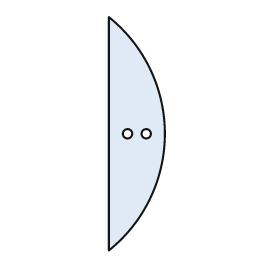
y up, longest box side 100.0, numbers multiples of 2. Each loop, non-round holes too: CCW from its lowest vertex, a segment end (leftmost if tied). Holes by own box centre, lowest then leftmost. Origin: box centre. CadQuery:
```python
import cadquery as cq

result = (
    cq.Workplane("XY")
    .moveTo(-12.0, -50.0)
    .threePointArc((12.0, 0.0), (-12.0, 50.0))
    .close()
    .moveTo(-4.0, 0.0)
    .circle(2.0)
    .moveTo(4.0, 0.0)
    .circle(2.0)
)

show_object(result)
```